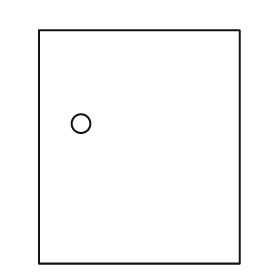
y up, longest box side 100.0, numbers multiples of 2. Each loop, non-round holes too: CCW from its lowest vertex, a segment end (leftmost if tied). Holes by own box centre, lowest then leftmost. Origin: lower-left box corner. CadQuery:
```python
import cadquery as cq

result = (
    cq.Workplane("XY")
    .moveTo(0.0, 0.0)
    .lineTo(86.0, 0.0)
    .lineTo(86.0, 100.0)
    .lineTo(0.0, 100.0)
    .close()
    .moveTo(18.0, 60.0)
    .circle(4.0)
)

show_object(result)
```